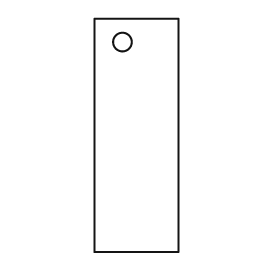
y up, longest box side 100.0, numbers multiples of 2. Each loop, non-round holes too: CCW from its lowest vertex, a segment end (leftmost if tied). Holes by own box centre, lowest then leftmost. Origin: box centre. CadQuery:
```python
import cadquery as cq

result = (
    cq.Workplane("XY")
    .moveTo(-18.0, -50.0)
    .lineTo(18.0, -50.0)
    .lineTo(18.0, 50.0)
    .lineTo(-18.0, 50.0)
    .close()
    .moveTo(-6.0, 40.0)
    .circle(4.0)
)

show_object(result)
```